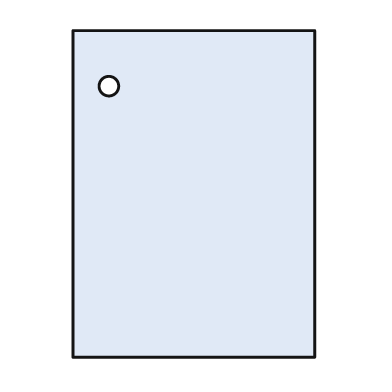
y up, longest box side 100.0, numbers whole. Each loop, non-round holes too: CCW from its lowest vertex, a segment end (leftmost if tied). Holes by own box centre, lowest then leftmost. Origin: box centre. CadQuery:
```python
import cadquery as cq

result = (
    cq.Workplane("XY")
    .moveTo(-37.0, -50.0)
    .lineTo(37.0, -50.0)
    .lineTo(37.0, 50.0)
    .lineTo(-37.0, 50.0)
    .close()
    .moveTo(-26.0, 33.0)
    .circle(3.0)
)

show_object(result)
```